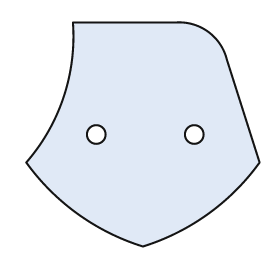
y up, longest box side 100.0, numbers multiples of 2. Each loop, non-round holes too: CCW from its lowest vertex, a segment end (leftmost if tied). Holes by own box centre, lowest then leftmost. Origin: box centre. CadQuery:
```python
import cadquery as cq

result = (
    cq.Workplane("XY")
    .moveTo(0.0, -48.0)
    .threePointArc((28.0, -34.0), (50.0, -12.0))
    .lineTo(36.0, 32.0)
    .threePointArc((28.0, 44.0), (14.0, 48.0))
    .lineTo(-30.0, 48.0)
    .threePointArc((-34.0, 16.0), (-50.0, -12.0))
    .threePointArc((-28.0, -34.0), (0.0, -48.0))
    .close()
    .moveTo(-20.0, 0.0)
    .circle(4.0)
    .moveTo(22.0, 0.0)
    .circle(4.0)
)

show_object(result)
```